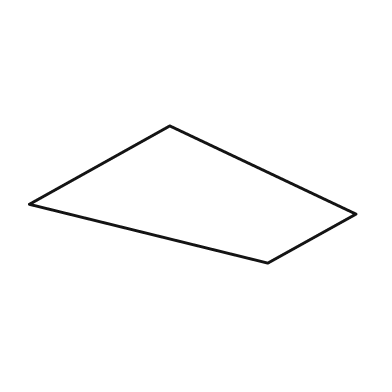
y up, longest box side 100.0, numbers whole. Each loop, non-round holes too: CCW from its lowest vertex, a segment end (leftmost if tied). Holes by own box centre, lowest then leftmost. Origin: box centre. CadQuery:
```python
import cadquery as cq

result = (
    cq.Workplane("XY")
    .moveTo(23.0, -21.0)
    .lineTo(50.0, -6.0)
    .lineTo(-7.0, 21.0)
    .lineTo(-50.0, -3.0)
    .close()
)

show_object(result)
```